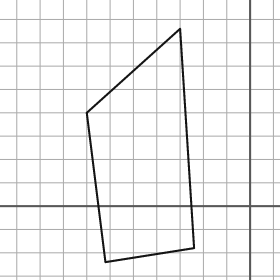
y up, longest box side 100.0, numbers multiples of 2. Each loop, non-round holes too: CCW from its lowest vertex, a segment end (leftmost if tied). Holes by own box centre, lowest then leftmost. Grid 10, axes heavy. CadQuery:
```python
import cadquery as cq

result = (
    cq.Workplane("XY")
    .moveTo(-62.0, -24.0)
    .lineTo(-24.0, -18.0)
    .lineTo(-30.0, 76.0)
    .lineTo(-70.0, 40.0)
    .close()
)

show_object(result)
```